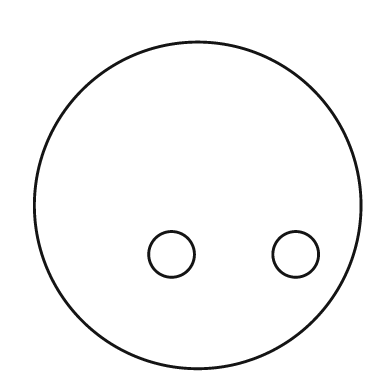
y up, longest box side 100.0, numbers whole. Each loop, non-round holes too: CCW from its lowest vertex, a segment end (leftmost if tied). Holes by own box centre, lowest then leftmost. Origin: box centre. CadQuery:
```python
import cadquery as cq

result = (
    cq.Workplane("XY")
    .moveTo(0.0, 0.0)
    .circle(50.0)
    .moveTo(-8.0, -15.0)
    .circle(7.0)
    .moveTo(30.0, -15.0)
    .circle(7.0)
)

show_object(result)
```